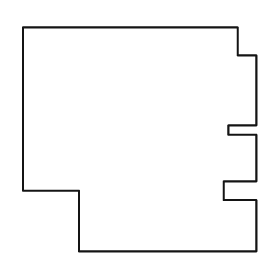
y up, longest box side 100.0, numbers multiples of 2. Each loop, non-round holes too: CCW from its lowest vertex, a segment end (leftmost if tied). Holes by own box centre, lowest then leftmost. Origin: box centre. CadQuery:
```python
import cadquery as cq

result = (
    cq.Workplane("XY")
    .moveTo(-26.0, -48.0)
    .lineTo(50.0, -48.0)
    .lineTo(50.0, -26.0)
    .lineTo(36.0, -26.0)
    .lineTo(36.0, -18.0)
    .lineTo(50.0, -18.0)
    .lineTo(50.0, 2.0)
    .lineTo(38.0, 2.0)
    .lineTo(38.0, 6.0)
    .lineTo(50.0, 6.0)
    .lineTo(50.0, 36.0)
    .lineTo(42.0, 36.0)
    .lineTo(42.0, 48.0)
    .lineTo(-50.0, 48.0)
    .lineTo(-50.0, -22.0)
    .lineTo(-26.0, -22.0)
    .close()
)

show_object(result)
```